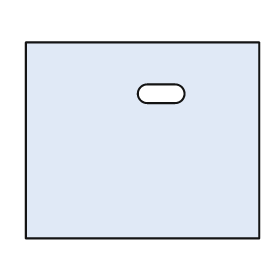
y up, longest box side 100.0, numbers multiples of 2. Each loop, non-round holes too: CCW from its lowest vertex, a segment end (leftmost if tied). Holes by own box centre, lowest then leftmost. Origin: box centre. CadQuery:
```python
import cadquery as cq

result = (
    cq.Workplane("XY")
    .moveTo(-50.0, -42.0)
    .lineTo(50.0, -42.0)
    .lineTo(50.0, 42.0)
    .lineTo(-50.0, 42.0)
    .close()
    .moveTo(2.0, 16.0)
    .lineTo(14.0, 16.0)
    .threePointArc((18.0, 20.0), (14.0, 24.0))
    .lineTo(2.0, 24.0)
    .threePointArc((-2.0, 20.0), (2.0, 16.0))
    .close()
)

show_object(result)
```